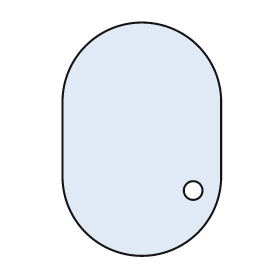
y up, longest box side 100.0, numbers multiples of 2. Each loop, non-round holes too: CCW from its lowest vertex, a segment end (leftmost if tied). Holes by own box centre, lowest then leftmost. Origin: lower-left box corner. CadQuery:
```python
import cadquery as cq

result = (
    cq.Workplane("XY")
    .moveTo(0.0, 34.0)
    .threePointArc((34.0, 0.0), (68.0, 34.0))
    .lineTo(68.0, 66.0)
    .threePointArc((34.0, 100.0), (0.0, 66.0))
    .close()
    .moveTo(56.0, 28.0)
    .circle(4.0)
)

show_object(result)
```